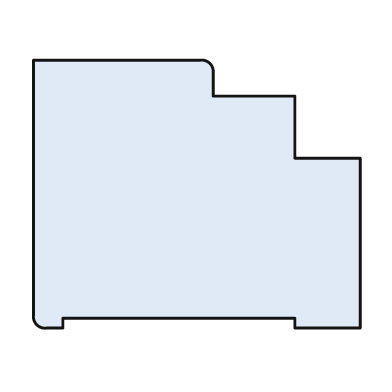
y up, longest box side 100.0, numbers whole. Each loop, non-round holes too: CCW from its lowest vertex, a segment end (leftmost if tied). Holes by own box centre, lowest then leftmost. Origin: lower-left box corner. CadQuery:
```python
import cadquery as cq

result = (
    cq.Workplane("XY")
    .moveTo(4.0, 0.0)
    .lineTo(9.0, 0.0)
    .lineTo(9.0, 3.0)
    .lineTo(80.0, 3.0)
    .lineTo(80.0, 0.0)
    .lineTo(100.0, 0.0)
    .lineTo(100.0, 52.0)
    .lineTo(80.0, 52.0)
    .lineTo(80.0, 71.0)
    .lineTo(55.0, 71.0)
    .lineTo(55.0, 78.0)
    .threePointArc((54.0, 81.0), (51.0, 82.0))
    .lineTo(0.0, 82.0)
    .lineTo(0.0, 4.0)
    .threePointArc((1.0, 1.0), (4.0, 0.0))
    .close()
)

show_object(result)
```